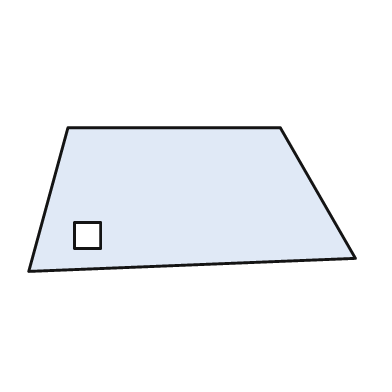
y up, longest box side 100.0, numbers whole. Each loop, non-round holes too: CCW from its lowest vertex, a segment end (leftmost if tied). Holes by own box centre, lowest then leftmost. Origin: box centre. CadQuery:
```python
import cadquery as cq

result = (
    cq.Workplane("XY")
    .moveTo(-50.0, -22.0)
    .lineTo(50.0, -18.0)
    .lineTo(27.0, 22.0)
    .lineTo(-38.0, 22.0)
    .close()
    .moveTo(-36.0, -15.0)
    .lineTo(-28.0, -15.0)
    .lineTo(-28.0, -7.0)
    .lineTo(-36.0, -7.0)
    .close()
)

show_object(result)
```